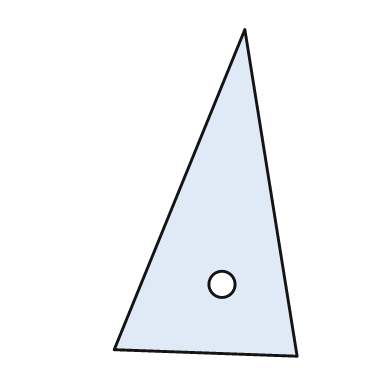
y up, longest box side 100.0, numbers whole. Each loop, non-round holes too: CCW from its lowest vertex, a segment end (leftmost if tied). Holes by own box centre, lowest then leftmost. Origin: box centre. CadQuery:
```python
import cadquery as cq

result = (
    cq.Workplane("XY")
    .moveTo(28.0, -50.0)
    .lineTo(12.0, 50.0)
    .lineTo(-28.0, -48.0)
    .close()
    .moveTo(5.0, -28.0)
    .circle(4.0)
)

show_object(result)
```